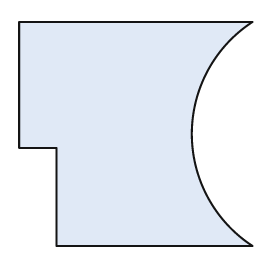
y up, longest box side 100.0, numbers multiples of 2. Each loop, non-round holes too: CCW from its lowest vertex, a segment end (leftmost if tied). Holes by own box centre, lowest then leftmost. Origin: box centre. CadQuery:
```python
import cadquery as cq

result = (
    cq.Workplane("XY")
    .moveTo(-34.0, -48.0)
    .lineTo(50.0, -48.0)
    .threePointArc((24.0, 0.0), (50.0, 48.0))
    .lineTo(-50.0, 48.0)
    .lineTo(-50.0, -6.0)
    .lineTo(-34.0, -6.0)
    .close()
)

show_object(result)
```